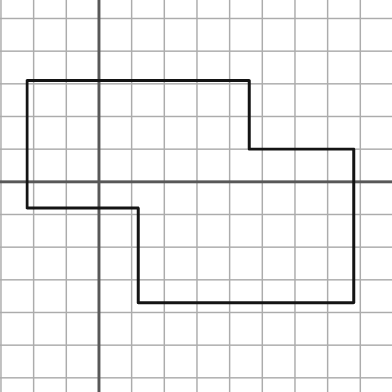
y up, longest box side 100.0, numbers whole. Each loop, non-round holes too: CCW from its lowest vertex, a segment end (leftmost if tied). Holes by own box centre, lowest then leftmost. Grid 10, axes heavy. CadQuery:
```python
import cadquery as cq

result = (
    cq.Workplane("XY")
    .moveTo(12.0, -37.0)
    .lineTo(78.0, -37.0)
    .lineTo(78.0, 10.0)
    .lineTo(46.0, 10.0)
    .lineTo(46.0, 31.0)
    .lineTo(-22.0, 31.0)
    .lineTo(-22.0, -8.0)
    .lineTo(12.0, -8.0)
    .close()
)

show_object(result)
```